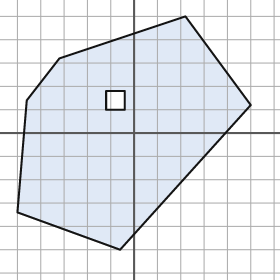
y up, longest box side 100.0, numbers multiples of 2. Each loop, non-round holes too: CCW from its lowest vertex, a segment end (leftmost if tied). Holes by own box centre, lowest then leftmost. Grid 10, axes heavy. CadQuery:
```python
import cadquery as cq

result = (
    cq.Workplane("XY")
    .moveTo(-6.0, -50.0)
    .lineTo(50.0, 12.0)
    .lineTo(22.0, 50.0)
    .lineTo(-32.0, 32.0)
    .lineTo(-46.0, 14.0)
    .lineTo(-50.0, -34.0)
    .close()
    .moveTo(-12.0, 10.0)
    .lineTo(-4.0, 10.0)
    .lineTo(-4.0, 18.0)
    .lineTo(-12.0, 18.0)
    .close()
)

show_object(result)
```